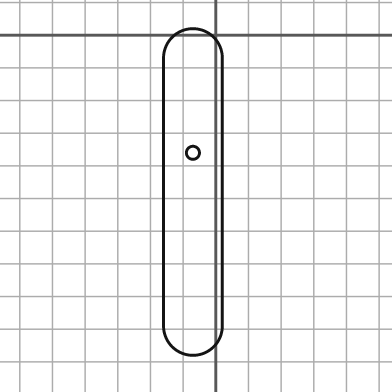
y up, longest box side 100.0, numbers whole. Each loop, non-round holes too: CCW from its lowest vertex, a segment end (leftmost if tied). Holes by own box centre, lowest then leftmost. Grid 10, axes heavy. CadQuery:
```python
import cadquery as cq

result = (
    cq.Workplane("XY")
    .moveTo(-16.0, -89.0)
    .threePointArc((-7.0, -98.0), (2.0, -89.0))
    .lineTo(2.0, -7.0)
    .threePointArc((-7.0, 2.0), (-16.0, -7.0))
    .close()
    .moveTo(-7.0, -36.0)
    .circle(2.0)
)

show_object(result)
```